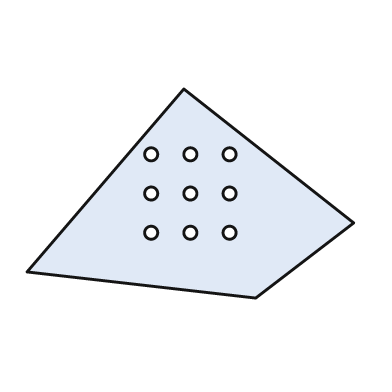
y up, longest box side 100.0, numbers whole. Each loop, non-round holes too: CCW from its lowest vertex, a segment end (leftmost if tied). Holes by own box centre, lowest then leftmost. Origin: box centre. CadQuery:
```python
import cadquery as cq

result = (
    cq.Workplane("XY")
    .moveTo(20.0, -32.0)
    .lineTo(50.0, -9.0)
    .lineTo(-2.0, 32.0)
    .lineTo(-50.0, -24.0)
    .close()
    .moveTo(-12.0, -12.0)
    .circle(2.0)
    .moveTo(0.0, -12.0)
    .circle(2.0)
    .moveTo(12.0, -12.0)
    .circle(2.0)
    .moveTo(-12.0, 0.0)
    .circle(2.0)
    .moveTo(0.0, 0.0)
    .circle(2.0)
    .moveTo(12.0, 0.0)
    .circle(2.0)
    .moveTo(-12.0, 12.0)
    .circle(2.0)
    .moveTo(0.0, 12.0)
    .circle(2.0)
    .moveTo(12.0, 12.0)
    .circle(2.0)
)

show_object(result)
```